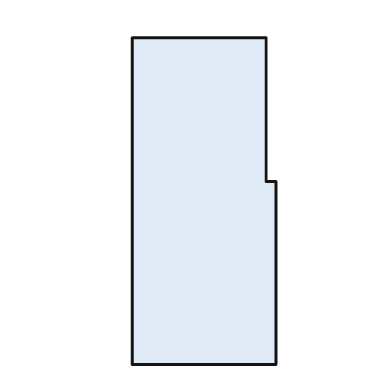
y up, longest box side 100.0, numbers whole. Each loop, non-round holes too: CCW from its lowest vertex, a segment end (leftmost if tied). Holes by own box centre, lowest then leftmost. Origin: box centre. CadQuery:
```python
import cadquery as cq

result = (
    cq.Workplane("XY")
    .moveTo(-22.0, -50.0)
    .lineTo(22.0, -50.0)
    .lineTo(22.0, 6.0)
    .lineTo(19.0, 6.0)
    .lineTo(19.0, 50.0)
    .lineTo(-22.0, 50.0)
    .close()
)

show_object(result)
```